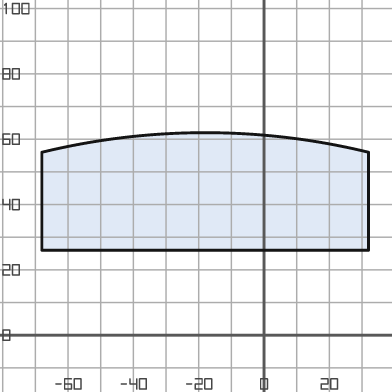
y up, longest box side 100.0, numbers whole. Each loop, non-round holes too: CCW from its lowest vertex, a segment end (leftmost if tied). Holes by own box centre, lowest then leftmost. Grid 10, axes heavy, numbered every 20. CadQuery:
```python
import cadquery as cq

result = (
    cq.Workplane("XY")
    .moveTo(-68.0, 26.0)
    .lineTo(32.0, 26.0)
    .lineTo(32.0, 56.0)
    .threePointArc((-18.0, 62.0), (-68.0, 56.0))
    .close()
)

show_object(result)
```